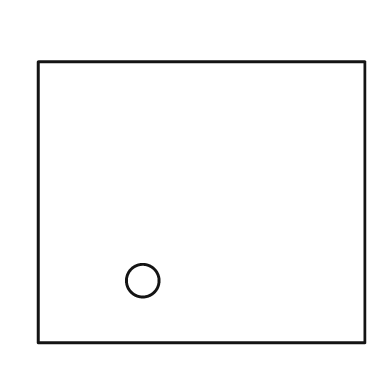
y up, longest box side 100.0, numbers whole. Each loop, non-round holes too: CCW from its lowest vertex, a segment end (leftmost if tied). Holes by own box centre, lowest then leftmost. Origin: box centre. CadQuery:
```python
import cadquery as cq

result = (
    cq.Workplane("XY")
    .moveTo(-50.0, -43.0)
    .lineTo(50.0, -43.0)
    .lineTo(50.0, 43.0)
    .lineTo(-50.0, 43.0)
    .close()
    .moveTo(-18.0, -24.0)
    .circle(5.0)
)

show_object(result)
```